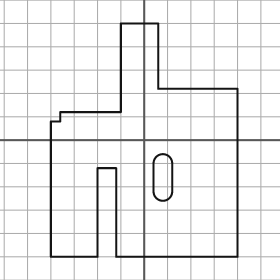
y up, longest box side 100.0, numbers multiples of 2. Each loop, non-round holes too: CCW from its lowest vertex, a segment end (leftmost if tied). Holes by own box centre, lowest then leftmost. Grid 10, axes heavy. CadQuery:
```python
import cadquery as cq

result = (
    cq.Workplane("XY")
    .moveTo(-40.0, -50.0)
    .lineTo(-20.0, -50.0)
    .lineTo(-20.0, -12.0)
    .lineTo(-12.0, -12.0)
    .lineTo(-12.0, -50.0)
    .lineTo(40.0, -50.0)
    .lineTo(40.0, 22.0)
    .lineTo(6.0, 22.0)
    .lineTo(6.0, 50.0)
    .lineTo(-10.0, 50.0)
    .lineTo(-10.0, 12.0)
    .lineTo(-36.0, 12.0)
    .lineTo(-36.0, 8.0)
    .lineTo(-40.0, 8.0)
    .close()
    .moveTo(4.0, -22.0)
    .threePointArc((8.0, -26.0), (12.0, -22.0))
    .lineTo(12.0, -10.0)
    .threePointArc((8.0, -6.0), (4.0, -10.0))
    .close()
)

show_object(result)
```